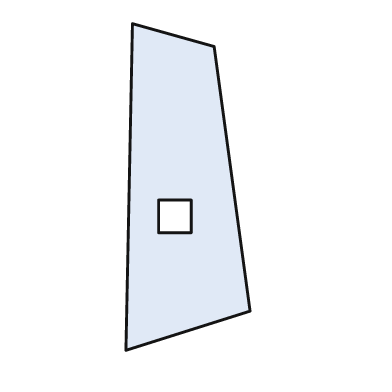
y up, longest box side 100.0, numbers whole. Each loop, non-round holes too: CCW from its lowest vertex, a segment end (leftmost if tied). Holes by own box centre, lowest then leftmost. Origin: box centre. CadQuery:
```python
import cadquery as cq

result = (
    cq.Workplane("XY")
    .moveTo(-19.0, -50.0)
    .lineTo(19.0, -38.0)
    .lineTo(8.0, 43.0)
    .lineTo(-17.0, 50.0)
    .close()
    .moveTo(-9.0, -14.0)
    .lineTo(1.0, -14.0)
    .lineTo(1.0, -4.0)
    .lineTo(-9.0, -4.0)
    .close()
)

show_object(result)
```